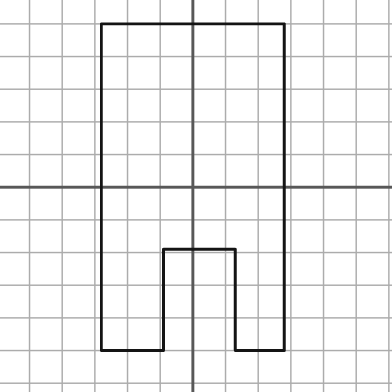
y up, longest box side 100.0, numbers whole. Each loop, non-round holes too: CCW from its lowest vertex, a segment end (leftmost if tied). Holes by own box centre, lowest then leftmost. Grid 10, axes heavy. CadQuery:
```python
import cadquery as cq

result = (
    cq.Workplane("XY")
    .moveTo(-28.0, -50.0)
    .lineTo(-9.0, -50.0)
    .lineTo(-9.0, -19.0)
    .lineTo(13.0, -19.0)
    .lineTo(13.0, -50.0)
    .lineTo(28.0, -50.0)
    .lineTo(28.0, 50.0)
    .lineTo(-28.0, 50.0)
    .close()
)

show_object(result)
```